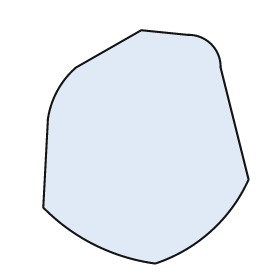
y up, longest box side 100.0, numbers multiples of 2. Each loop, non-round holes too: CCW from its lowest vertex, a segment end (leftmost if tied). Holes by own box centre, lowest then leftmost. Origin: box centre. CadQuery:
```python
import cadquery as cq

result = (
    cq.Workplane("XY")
    .moveTo(4.0, -50.0)
    .threePointArc((28.0, -36.0), (44.0, -14.0))
    .lineTo(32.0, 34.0)
    .threePointArc((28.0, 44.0), (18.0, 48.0))
    .lineTo(-2.0, 50.0)
    .lineTo(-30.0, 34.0)
    .threePointArc((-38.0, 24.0), (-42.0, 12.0))
    .lineTo(-44.0, -26.0)
    .threePointArc((-22.0, -42.0), (4.0, -50.0))
    .close()
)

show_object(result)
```